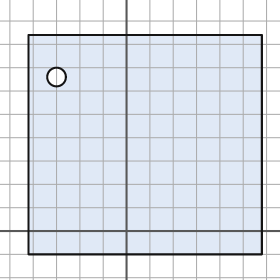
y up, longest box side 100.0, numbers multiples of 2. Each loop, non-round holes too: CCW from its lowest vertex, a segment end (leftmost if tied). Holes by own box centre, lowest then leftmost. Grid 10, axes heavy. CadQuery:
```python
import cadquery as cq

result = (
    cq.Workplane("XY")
    .moveTo(-42.0, -10.0)
    .lineTo(58.0, -10.0)
    .lineTo(58.0, 84.0)
    .lineTo(-42.0, 84.0)
    .close()
    .moveTo(-30.0, 66.0)
    .circle(4.0)
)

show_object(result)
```